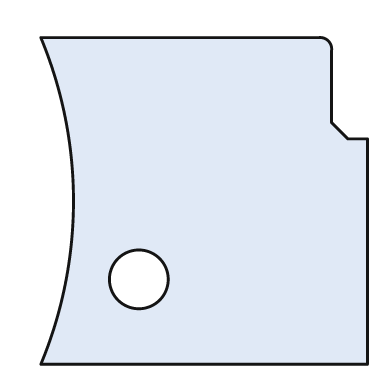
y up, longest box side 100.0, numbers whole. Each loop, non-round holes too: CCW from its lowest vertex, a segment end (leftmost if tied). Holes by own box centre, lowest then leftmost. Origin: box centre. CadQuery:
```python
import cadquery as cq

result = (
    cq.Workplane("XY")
    .moveTo(-50.0, -50.0)
    .lineTo(50.0, -50.0)
    .lineTo(50.0, 19.0)
    .lineTo(44.0, 19.0)
    .lineTo(39.0, 24.0)
    .lineTo(39.0, 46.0)
    .threePointArc((38.0, 49.0), (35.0, 50.0))
    .lineTo(-50.0, 50.0)
    .threePointArc((-40.0, 0.0), (-50.0, -50.0))
    .close()
    .moveTo(-20.0, -24.0)
    .circle(9.0)
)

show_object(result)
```